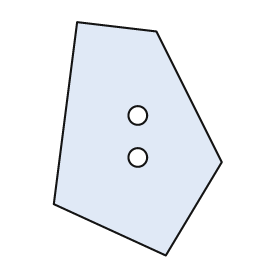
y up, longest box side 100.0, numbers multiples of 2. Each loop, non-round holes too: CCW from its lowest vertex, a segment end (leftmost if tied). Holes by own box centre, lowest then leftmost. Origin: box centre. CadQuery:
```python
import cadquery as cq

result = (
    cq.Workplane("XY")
    .moveTo(12.0, -50.0)
    .lineTo(36.0, -10.0)
    .lineTo(8.0, 46.0)
    .lineTo(-26.0, 50.0)
    .lineTo(-36.0, -28.0)
    .close()
    .moveTo(0.0, -8.0)
    .circle(4.0)
    .moveTo(0.0, 10.0)
    .circle(4.0)
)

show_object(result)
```